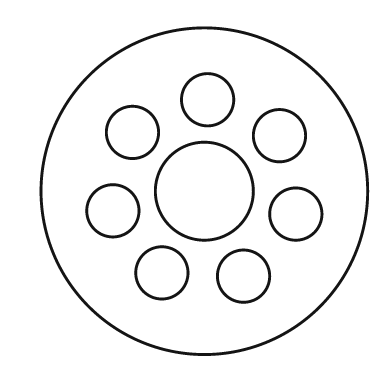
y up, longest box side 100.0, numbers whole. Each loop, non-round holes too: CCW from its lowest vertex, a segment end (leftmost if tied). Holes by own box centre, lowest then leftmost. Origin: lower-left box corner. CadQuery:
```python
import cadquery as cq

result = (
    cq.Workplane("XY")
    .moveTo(50.0, 50.0)
    .circle(50.0)
    .moveTo(62.0, 24.0)
    .circle(8.0)
    .moveTo(37.0, 25.0)
    .circle(8.0)
    .moveTo(78.0, 43.0)
    .circle(8.0)
    .moveTo(22.0, 44.0)
    .circle(8.0)
    .moveTo(50.0, 50.0)
    .circle(15.0)
    .moveTo(73.0, 67.0)
    .circle(8.0)
    .moveTo(28.0, 68.0)
    .circle(8.0)
    .moveTo(51.0, 78.0)
    .circle(8.0)
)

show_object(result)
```